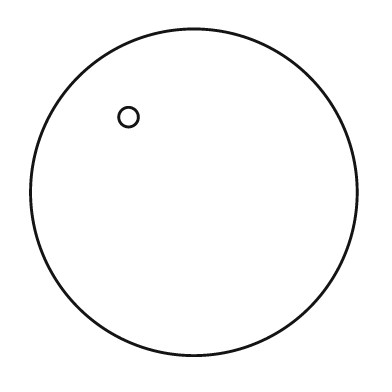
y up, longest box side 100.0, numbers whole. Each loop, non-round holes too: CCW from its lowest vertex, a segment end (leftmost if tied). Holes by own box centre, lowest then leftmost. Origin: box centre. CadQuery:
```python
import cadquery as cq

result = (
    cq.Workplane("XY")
    .moveTo(0.0, 0.0)
    .circle(50.0)
    .moveTo(-20.0, 23.0)
    .circle(3.0)
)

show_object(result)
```